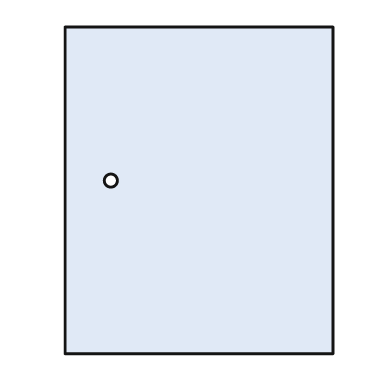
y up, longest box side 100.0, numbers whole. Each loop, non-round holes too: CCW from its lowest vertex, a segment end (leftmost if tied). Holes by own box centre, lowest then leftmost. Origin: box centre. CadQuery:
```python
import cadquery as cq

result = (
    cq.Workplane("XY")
    .moveTo(-41.0, -50.0)
    .lineTo(41.0, -50.0)
    .lineTo(41.0, 50.0)
    .lineTo(-41.0, 50.0)
    .close()
    .moveTo(-27.0, 3.0)
    .circle(2.0)
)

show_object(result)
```